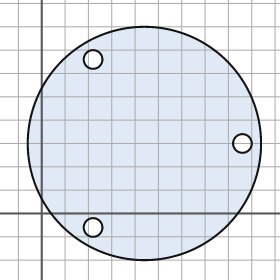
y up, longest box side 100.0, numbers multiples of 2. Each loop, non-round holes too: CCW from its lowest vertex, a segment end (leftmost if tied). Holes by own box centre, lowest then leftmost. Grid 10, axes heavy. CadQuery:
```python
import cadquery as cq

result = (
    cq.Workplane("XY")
    .moveTo(44.0, 30.0)
    .circle(50.0)
    .moveTo(22.0, -6.0)
    .circle(4.0)
    .moveTo(86.0, 30.0)
    .circle(4.0)
    .moveTo(22.0, 66.0)
    .circle(4.0)
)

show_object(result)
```